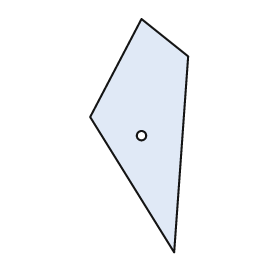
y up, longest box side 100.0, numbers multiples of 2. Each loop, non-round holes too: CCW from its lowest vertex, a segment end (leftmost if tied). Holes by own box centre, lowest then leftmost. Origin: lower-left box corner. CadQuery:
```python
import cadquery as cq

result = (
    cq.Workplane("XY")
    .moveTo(36.0, 0.0)
    .lineTo(42.0, 84.0)
    .lineTo(22.0, 100.0)
    .lineTo(0.0, 58.0)
    .close()
    .moveTo(22.0, 50.0)
    .circle(2.0)
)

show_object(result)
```